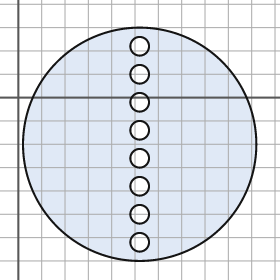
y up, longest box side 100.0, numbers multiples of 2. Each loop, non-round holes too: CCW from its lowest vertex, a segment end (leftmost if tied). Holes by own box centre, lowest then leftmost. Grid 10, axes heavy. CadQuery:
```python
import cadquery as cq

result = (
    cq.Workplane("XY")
    .moveTo(52.0, -20.0)
    .circle(50.0)
    .moveTo(52.0, -62.0)
    .circle(4.0)
    .moveTo(52.0, -50.0)
    .circle(4.0)
    .moveTo(52.0, -38.0)
    .circle(4.0)
    .moveTo(52.0, -26.0)
    .circle(4.0)
    .moveTo(52.0, -14.0)
    .circle(4.0)
    .moveTo(52.0, -2.0)
    .circle(4.0)
    .moveTo(52.0, 10.0)
    .circle(4.0)
    .moveTo(52.0, 22.0)
    .circle(4.0)
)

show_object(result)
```